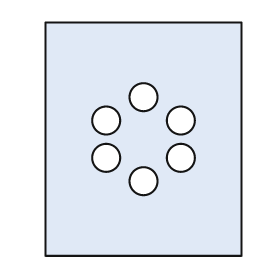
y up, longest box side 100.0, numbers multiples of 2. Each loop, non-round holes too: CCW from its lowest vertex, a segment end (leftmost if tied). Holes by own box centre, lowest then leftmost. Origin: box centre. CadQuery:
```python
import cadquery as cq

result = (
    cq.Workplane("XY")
    .moveTo(-42.0, -50.0)
    .lineTo(42.0, -50.0)
    .lineTo(42.0, 50.0)
    .lineTo(-42.0, 50.0)
    .close()
    .moveTo(0.0, -18.0)
    .circle(6.0)
    .moveTo(-16.0, -8.0)
    .circle(6.0)
    .moveTo(16.0, -8.0)
    .circle(6.0)
    .moveTo(-16.0, 8.0)
    .circle(6.0)
    .moveTo(16.0, 8.0)
    .circle(6.0)
    .moveTo(0.0, 18.0)
    .circle(6.0)
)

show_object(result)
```